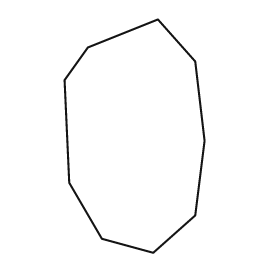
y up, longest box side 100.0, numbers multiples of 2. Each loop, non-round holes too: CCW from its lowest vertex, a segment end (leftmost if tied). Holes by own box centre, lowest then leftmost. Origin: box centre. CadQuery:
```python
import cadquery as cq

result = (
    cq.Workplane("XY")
    .moveTo(8.0, -50.0)
    .lineTo(26.0, -34.0)
    .lineTo(30.0, -2.0)
    .lineTo(26.0, 32.0)
    .lineTo(10.0, 50.0)
    .lineTo(-20.0, 38.0)
    .lineTo(-30.0, 24.0)
    .lineTo(-28.0, -20.0)
    .lineTo(-14.0, -44.0)
    .close()
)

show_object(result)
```